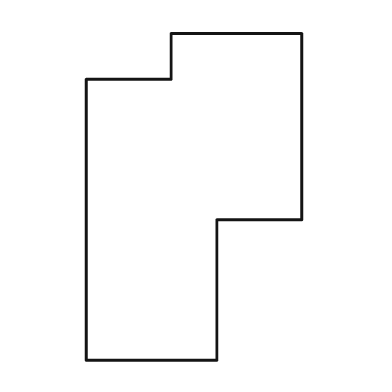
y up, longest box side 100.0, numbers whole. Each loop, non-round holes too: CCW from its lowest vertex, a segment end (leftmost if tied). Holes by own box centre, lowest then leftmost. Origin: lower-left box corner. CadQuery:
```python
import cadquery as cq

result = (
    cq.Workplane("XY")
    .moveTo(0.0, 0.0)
    .lineTo(40.0, 0.0)
    .lineTo(40.0, 43.0)
    .lineTo(66.0, 43.0)
    .lineTo(66.0, 100.0)
    .lineTo(26.0, 100.0)
    .lineTo(26.0, 86.0)
    .lineTo(0.0, 86.0)
    .close()
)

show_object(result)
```